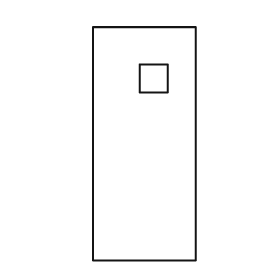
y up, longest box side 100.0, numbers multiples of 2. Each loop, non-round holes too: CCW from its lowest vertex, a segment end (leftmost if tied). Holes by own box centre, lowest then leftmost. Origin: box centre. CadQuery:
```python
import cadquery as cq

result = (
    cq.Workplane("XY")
    .moveTo(-22.0, -50.0)
    .lineTo(22.0, -50.0)
    .lineTo(22.0, 50.0)
    .lineTo(-22.0, 50.0)
    .close()
    .moveTo(-2.0, 22.0)
    .lineTo(10.0, 22.0)
    .lineTo(10.0, 34.0)
    .lineTo(-2.0, 34.0)
    .close()
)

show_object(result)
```